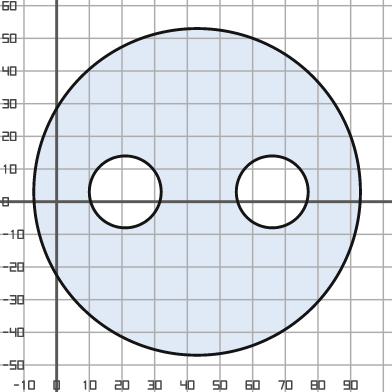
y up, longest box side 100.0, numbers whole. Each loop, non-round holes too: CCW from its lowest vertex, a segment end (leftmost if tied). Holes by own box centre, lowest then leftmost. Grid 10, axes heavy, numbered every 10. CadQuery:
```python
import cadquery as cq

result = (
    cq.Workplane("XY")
    .moveTo(43.0, 3.0)
    .circle(50.0)
    .moveTo(21.0, 3.0)
    .circle(11.0)
    .moveTo(66.0, 3.0)
    .circle(11.0)
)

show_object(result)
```